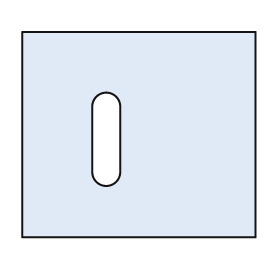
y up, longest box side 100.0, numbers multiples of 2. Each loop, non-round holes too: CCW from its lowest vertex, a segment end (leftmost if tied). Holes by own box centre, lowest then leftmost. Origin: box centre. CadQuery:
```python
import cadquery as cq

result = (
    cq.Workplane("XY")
    .moveTo(-50.0, -44.0)
    .lineTo(50.0, -44.0)
    .lineTo(50.0, 44.0)
    .lineTo(-50.0, 44.0)
    .close()
    .moveTo(-20.0, -16.0)
    .threePointArc((-14.0, -22.0), (-8.0, -16.0))
    .lineTo(-8.0, 12.0)
    .threePointArc((-14.0, 18.0), (-20.0, 12.0))
    .close()
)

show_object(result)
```